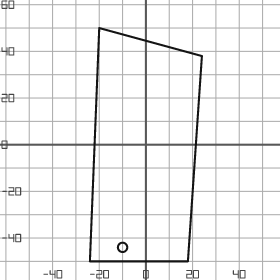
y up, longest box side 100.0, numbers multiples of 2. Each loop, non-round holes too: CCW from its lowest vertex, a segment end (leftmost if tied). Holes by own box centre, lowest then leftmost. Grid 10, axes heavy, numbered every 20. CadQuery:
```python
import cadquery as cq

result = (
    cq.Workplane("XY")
    .moveTo(-24.0, -50.0)
    .lineTo(18.0, -50.0)
    .lineTo(24.0, 38.0)
    .lineTo(-20.0, 50.0)
    .close()
    .moveTo(-10.0, -44.0)
    .circle(2.0)
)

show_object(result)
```